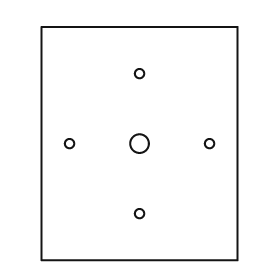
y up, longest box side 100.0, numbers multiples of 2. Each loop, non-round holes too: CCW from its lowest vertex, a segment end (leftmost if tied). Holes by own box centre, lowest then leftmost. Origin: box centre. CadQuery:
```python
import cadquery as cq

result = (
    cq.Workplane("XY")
    .moveTo(-42.0, -50.0)
    .lineTo(42.0, -50.0)
    .lineTo(42.0, 50.0)
    .lineTo(-42.0, 50.0)
    .close()
    .moveTo(0.0, -30.0)
    .circle(2.0)
    .moveTo(-30.0, 0.0)
    .circle(2.0)
    .moveTo(0.0, 0.0)
    .circle(4.0)
    .moveTo(30.0, 0.0)
    .circle(2.0)
    .moveTo(0.0, 30.0)
    .circle(2.0)
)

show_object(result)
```